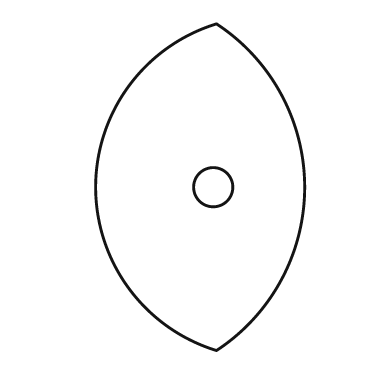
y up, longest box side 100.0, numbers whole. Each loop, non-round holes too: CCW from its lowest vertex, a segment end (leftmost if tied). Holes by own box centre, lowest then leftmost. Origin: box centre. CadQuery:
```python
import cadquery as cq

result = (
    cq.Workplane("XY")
    .moveTo(5.0, -50.0)
    .threePointArc((32.0, 0.0), (5.0, 50.0))
    .threePointArc((-32.0, 0.0), (5.0, -50.0))
    .close()
    .moveTo(4.0, 0.0)
    .circle(6.0)
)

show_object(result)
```